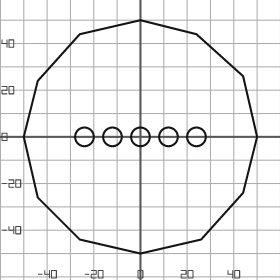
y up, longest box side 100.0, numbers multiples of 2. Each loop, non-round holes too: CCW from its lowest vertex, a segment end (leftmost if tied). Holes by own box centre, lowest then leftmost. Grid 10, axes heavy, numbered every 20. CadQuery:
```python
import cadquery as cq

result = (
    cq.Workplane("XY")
    .moveTo(0.0, -50.0)
    .lineTo(26.0, -44.0)
    .lineTo(44.0, -24.0)
    .lineTo(50.0, 0.0)
    .lineTo(44.0, 26.0)
    .lineTo(24.0, 44.0)
    .lineTo(0.0, 50.0)
    .lineTo(-26.0, 44.0)
    .lineTo(-44.0, 24.0)
    .lineTo(-50.0, 0.0)
    .lineTo(-44.0, -26.0)
    .lineTo(-26.0, -44.0)
    .close()
    .moveTo(-24.0, 0.0)
    .circle(4.0)
    .moveTo(-12.0, 0.0)
    .circle(4.0)
    .moveTo(0.0, 0.0)
    .circle(4.0)
    .moveTo(12.0, 0.0)
    .circle(4.0)
    .moveTo(24.0, 0.0)
    .circle(4.0)
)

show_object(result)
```